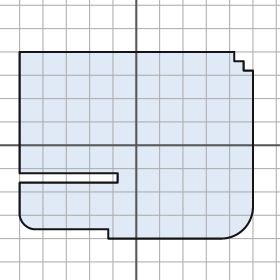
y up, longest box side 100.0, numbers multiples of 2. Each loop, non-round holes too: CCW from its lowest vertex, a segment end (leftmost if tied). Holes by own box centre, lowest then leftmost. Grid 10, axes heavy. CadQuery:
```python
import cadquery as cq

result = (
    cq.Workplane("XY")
    .moveTo(-12.0, -40.0)
    .lineTo(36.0, -40.0)
    .threePointArc((46.0, -36.0), (50.0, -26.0))
    .lineTo(50.0, 32.0)
    .lineTo(46.0, 32.0)
    .lineTo(46.0, 36.0)
    .lineTo(42.0, 36.0)
    .lineTo(42.0, 40.0)
    .lineTo(-50.0, 40.0)
    .lineTo(-50.0, -12.0)
    .lineTo(-8.0, -12.0)
    .lineTo(-8.0, -16.0)
    .lineTo(-50.0, -16.0)
    .lineTo(-50.0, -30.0)
    .threePointArc((-48.0, -34.0), (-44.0, -36.0))
    .lineTo(-12.0, -36.0)
    .close()
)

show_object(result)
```